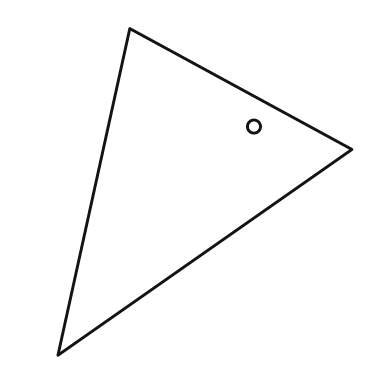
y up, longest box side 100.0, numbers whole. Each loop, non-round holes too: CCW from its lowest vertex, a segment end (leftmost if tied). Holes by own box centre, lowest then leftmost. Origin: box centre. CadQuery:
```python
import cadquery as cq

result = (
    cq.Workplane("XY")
    .moveTo(-45.0, -50.0)
    .lineTo(45.0, 13.0)
    .lineTo(-23.0, 50.0)
    .close()
    .moveTo(15.0, 20.0)
    .circle(2.0)
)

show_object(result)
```